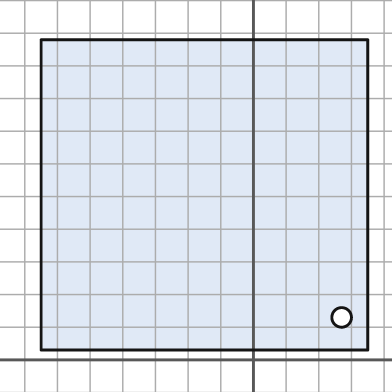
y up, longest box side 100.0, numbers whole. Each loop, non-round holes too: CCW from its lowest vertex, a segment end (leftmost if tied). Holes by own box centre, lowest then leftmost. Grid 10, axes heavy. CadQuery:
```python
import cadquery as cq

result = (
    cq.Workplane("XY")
    .moveTo(-65.0, 3.0)
    .lineTo(35.0, 3.0)
    .lineTo(35.0, 98.0)
    .lineTo(-65.0, 98.0)
    .close()
    .moveTo(27.0, 13.0)
    .circle(3.0)
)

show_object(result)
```